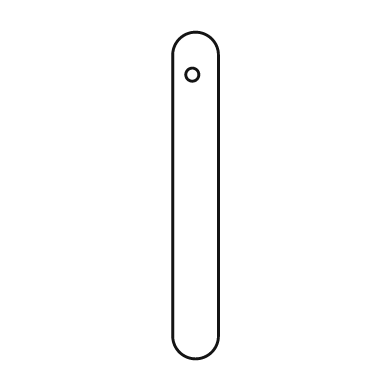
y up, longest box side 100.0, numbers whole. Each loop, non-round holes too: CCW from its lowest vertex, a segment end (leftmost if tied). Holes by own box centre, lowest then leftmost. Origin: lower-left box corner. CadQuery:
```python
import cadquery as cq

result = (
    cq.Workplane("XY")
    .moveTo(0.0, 7.0)
    .threePointArc((7.0, 0.0), (14.0, 7.0))
    .lineTo(14.0, 93.0)
    .threePointArc((7.0, 100.0), (0.0, 93.0))
    .close()
    .moveTo(6.0, 87.0)
    .circle(2.0)
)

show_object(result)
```